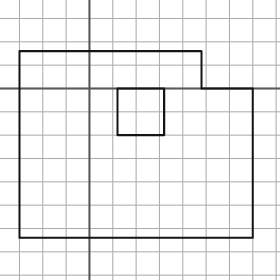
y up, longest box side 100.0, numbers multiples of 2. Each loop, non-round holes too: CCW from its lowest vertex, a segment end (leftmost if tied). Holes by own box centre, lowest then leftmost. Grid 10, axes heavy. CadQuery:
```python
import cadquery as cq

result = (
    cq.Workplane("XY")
    .moveTo(-30.0, -64.0)
    .lineTo(70.0, -64.0)
    .lineTo(70.0, 0.0)
    .lineTo(48.0, 0.0)
    .lineTo(48.0, 16.0)
    .lineTo(-30.0, 16.0)
    .close()
    .moveTo(12.0, -20.0)
    .lineTo(32.0, -20.0)
    .lineTo(32.0, 0.0)
    .lineTo(12.0, 0.0)
    .close()
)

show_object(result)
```